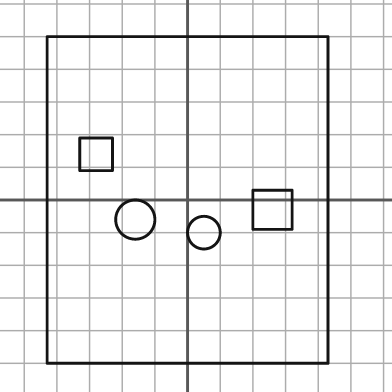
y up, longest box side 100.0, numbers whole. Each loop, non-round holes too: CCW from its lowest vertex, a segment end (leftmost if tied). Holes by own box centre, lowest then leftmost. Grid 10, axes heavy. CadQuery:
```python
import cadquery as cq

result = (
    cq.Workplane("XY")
    .moveTo(-43.0, -50.0)
    .lineTo(43.0, -50.0)
    .lineTo(43.0, 50.0)
    .lineTo(-43.0, 50.0)
    .close()
    .moveTo(5.0, -10.0)
    .circle(5.0)
    .moveTo(-16.0, -6.0)
    .circle(6.0)
    .moveTo(20.0, -9.0)
    .lineTo(32.0, -9.0)
    .lineTo(32.0, 3.0)
    .lineTo(20.0, 3.0)
    .close()
    .moveTo(-33.0, 9.0)
    .lineTo(-23.0, 9.0)
    .lineTo(-23.0, 19.0)
    .lineTo(-33.0, 19.0)
    .close()
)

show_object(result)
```